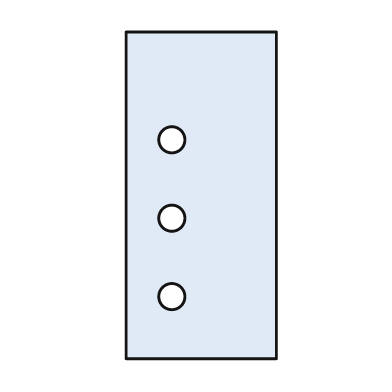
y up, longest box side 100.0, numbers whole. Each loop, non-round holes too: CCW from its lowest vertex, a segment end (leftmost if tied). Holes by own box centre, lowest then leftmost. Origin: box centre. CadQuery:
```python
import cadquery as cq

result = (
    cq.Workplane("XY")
    .moveTo(-23.0, -50.0)
    .lineTo(23.0, -50.0)
    .lineTo(23.0, 50.0)
    .lineTo(-23.0, 50.0)
    .close()
    .moveTo(-9.0, -31.0)
    .circle(4.0)
    .moveTo(-9.0, -7.0)
    .circle(4.0)
    .moveTo(-9.0, 17.0)
    .circle(4.0)
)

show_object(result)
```